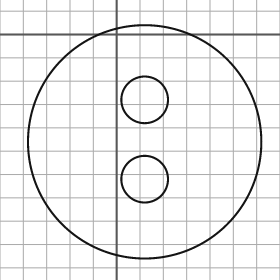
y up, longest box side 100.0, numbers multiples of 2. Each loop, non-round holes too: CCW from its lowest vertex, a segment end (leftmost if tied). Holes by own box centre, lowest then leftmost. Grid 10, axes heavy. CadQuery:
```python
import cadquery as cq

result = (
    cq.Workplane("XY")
    .moveTo(12.0, -46.0)
    .circle(50.0)
    .moveTo(12.0, -62.0)
    .circle(10.0)
    .moveTo(12.0, -28.0)
    .circle(10.0)
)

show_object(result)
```